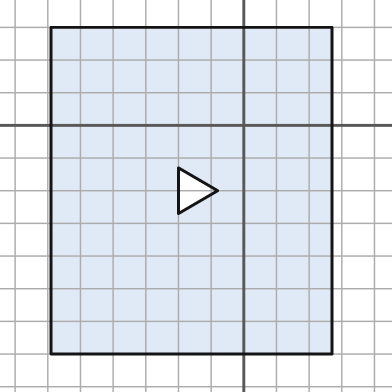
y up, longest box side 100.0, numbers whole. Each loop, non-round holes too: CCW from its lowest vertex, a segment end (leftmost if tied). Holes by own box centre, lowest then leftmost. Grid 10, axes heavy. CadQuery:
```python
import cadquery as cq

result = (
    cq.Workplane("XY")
    .moveTo(-59.0, -70.0)
    .lineTo(27.0, -70.0)
    .lineTo(27.0, 30.0)
    .lineTo(-59.0, 30.0)
    .close()
    .moveTo(-20.0, -27.0)
    .lineTo(-8.0, -20.0)
    .lineTo(-20.0, -13.0)
    .close()
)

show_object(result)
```